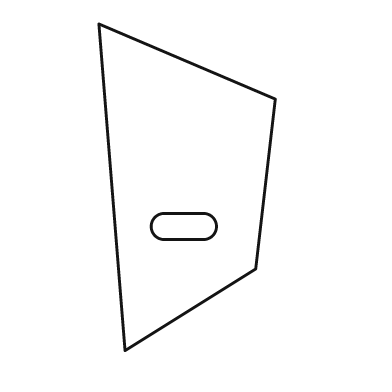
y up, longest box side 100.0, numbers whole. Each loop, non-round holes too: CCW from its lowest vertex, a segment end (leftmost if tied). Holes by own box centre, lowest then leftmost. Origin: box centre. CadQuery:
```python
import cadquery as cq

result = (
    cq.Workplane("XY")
    .moveTo(-19.0, -50.0)
    .lineTo(21.0, -25.0)
    .lineTo(27.0, 27.0)
    .lineTo(-27.0, 50.0)
    .close()
    .moveTo(-7.0, -16.0)
    .lineTo(5.0, -16.0)
    .threePointArc((9.0, -12.0), (5.0, -8.0))
    .lineTo(-7.0, -8.0)
    .threePointArc((-11.0, -12.0), (-7.0, -16.0))
    .close()
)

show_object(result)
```